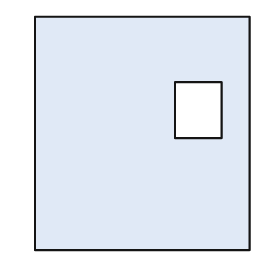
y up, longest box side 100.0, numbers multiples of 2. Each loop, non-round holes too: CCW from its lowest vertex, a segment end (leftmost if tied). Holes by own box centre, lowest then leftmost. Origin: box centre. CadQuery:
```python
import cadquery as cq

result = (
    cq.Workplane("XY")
    .moveTo(-46.0, -50.0)
    .lineTo(46.0, -50.0)
    .lineTo(46.0, 50.0)
    .lineTo(-46.0, 50.0)
    .close()
    .moveTo(14.0, -2.0)
    .lineTo(34.0, -2.0)
    .lineTo(34.0, 22.0)
    .lineTo(14.0, 22.0)
    .close()
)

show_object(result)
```